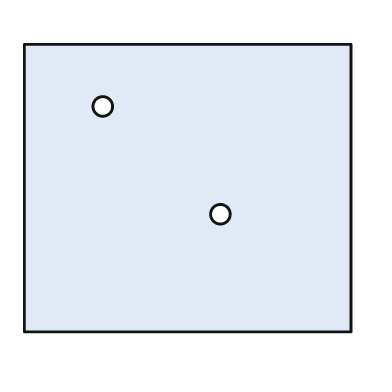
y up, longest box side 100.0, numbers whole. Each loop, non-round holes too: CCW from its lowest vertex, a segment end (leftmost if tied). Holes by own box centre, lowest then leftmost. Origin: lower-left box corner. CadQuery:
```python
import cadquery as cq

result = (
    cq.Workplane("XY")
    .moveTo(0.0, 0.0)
    .lineTo(100.0, 0.0)
    .lineTo(100.0, 88.0)
    .lineTo(0.0, 88.0)
    .close()
    .moveTo(60.0, 36.0)
    .circle(3.0)
    .moveTo(24.0, 69.0)
    .circle(3.0)
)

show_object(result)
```